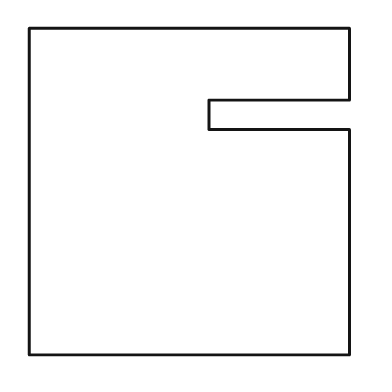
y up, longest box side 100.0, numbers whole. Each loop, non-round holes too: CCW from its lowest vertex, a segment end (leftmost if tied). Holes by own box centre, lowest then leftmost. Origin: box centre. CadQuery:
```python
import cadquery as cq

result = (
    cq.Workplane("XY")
    .moveTo(-49.0, -50.0)
    .lineTo(49.0, -50.0)
    .lineTo(49.0, 19.0)
    .lineTo(6.0, 19.0)
    .lineTo(6.0, 28.0)
    .lineTo(49.0, 28.0)
    .lineTo(49.0, 50.0)
    .lineTo(-49.0, 50.0)
    .close()
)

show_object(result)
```